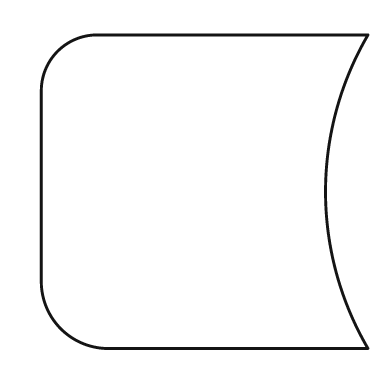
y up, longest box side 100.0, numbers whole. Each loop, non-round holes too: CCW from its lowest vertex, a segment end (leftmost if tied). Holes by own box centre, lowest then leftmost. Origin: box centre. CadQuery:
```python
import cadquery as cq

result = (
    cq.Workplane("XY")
    .moveTo(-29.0, -48.0)
    .lineTo(50.0, -48.0)
    .threePointArc((37.0, 0.0), (50.0, 48.0))
    .lineTo(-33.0, 48.0)
    .threePointArc((-45.0, 43.0), (-50.0, 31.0))
    .lineTo(-50.0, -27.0)
    .threePointArc((-44.0, -42.0), (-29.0, -48.0))
    .close()
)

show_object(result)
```